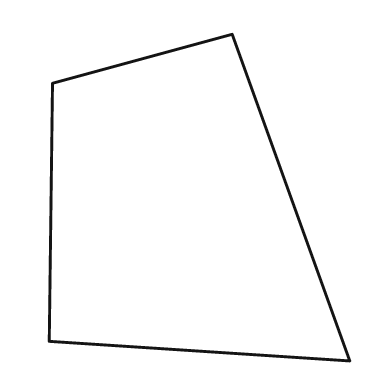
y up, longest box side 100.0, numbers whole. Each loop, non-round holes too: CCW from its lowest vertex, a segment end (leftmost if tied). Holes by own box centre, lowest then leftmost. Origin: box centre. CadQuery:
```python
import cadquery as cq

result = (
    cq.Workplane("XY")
    .moveTo(46.0, -50.0)
    .lineTo(10.0, 50.0)
    .lineTo(-45.0, 35.0)
    .lineTo(-46.0, -44.0)
    .close()
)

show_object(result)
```